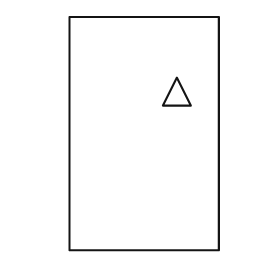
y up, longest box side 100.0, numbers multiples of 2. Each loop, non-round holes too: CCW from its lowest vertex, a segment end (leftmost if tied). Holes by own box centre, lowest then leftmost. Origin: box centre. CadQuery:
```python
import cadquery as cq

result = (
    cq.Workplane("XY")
    .moveTo(-32.0, -50.0)
    .lineTo(32.0, -50.0)
    .lineTo(32.0, 50.0)
    .lineTo(-32.0, 50.0)
    .close()
    .moveTo(8.0, 12.0)
    .lineTo(20.0, 12.0)
    .lineTo(14.0, 24.0)
    .close()
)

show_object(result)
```